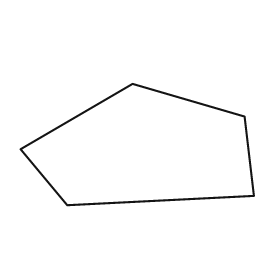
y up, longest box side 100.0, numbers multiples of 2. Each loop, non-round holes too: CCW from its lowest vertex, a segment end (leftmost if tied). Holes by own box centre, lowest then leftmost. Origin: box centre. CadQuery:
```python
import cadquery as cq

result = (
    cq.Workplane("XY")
    .moveTo(-30.0, -26.0)
    .lineTo(50.0, -22.0)
    .lineTo(46.0, 12.0)
    .lineTo(-2.0, 26.0)
    .lineTo(-50.0, -2.0)
    .close()
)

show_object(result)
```